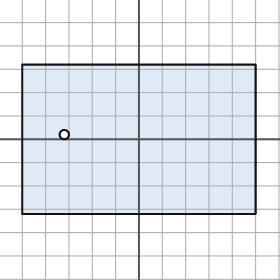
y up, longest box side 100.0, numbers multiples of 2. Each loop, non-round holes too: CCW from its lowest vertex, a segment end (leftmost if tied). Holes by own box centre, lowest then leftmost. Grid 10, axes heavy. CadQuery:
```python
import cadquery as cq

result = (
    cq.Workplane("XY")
    .moveTo(-50.0, -32.0)
    .lineTo(50.0, -32.0)
    .lineTo(50.0, 32.0)
    .lineTo(-50.0, 32.0)
    .close()
    .moveTo(-32.0, 2.0)
    .circle(2.0)
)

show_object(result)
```